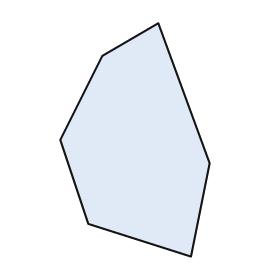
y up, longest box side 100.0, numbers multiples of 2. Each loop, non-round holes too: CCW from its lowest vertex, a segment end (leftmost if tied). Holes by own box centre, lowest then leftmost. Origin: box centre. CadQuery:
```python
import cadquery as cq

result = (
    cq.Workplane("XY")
    .moveTo(24.0, -50.0)
    .lineTo(32.0, -10.0)
    .lineTo(10.0, 50.0)
    .lineTo(-14.0, 36.0)
    .lineTo(-32.0, 0.0)
    .lineTo(-20.0, -36.0)
    .close()
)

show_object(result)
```